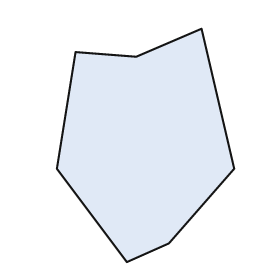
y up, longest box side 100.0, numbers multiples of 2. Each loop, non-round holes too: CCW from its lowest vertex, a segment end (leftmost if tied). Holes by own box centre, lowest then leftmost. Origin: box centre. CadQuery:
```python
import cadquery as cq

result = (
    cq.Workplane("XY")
    .moveTo(-8.0, -50.0)
    .lineTo(10.0, -42.0)
    .lineTo(38.0, -10.0)
    .lineTo(24.0, 50.0)
    .lineTo(-4.0, 38.0)
    .lineTo(-30.0, 40.0)
    .lineTo(-38.0, -10.0)
    .close()
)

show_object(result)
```